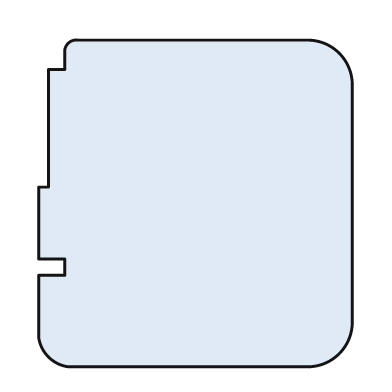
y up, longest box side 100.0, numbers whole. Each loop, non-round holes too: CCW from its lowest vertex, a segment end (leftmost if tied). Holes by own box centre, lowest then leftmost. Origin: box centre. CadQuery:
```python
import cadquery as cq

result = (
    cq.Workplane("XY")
    .moveTo(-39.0, -50.0)
    .lineTo(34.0, -50.0)
    .threePointArc((44.0, -46.0), (48.0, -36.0))
    .lineTo(48.0, 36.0)
    .threePointArc((44.0, 46.0), (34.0, 50.0))
    .lineTo(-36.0, 50.0)
    .threePointArc((-39.0, 49.0), (-40.0, 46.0))
    .lineTo(-40.0, 41.0)
    .lineTo(-45.0, 41.0)
    .lineTo(-45.0, 5.0)
    .lineTo(-48.0, 5.0)
    .lineTo(-48.0, -17.0)
    .lineTo(-40.0, -17.0)
    .lineTo(-40.0, -22.0)
    .lineTo(-48.0, -22.0)
    .lineTo(-48.0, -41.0)
    .threePointArc((-45.0, -47.0), (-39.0, -50.0))
    .close()
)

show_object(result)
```